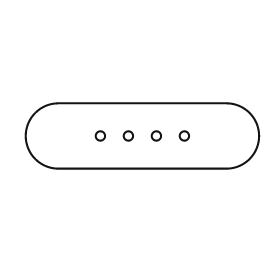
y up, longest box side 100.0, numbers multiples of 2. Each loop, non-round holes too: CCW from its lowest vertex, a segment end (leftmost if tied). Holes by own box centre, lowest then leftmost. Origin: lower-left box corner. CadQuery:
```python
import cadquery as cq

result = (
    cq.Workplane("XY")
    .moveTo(14.0, 0.0)
    .lineTo(86.0, 0.0)
    .threePointArc((100.0, 14.0), (86.0, 28.0))
    .lineTo(14.0, 28.0)
    .threePointArc((0.0, 14.0), (14.0, 0.0))
    .close()
    .moveTo(32.0, 14.0)
    .circle(2.0)
    .moveTo(44.0, 14.0)
    .circle(2.0)
    .moveTo(56.0, 14.0)
    .circle(2.0)
    .moveTo(68.0, 14.0)
    .circle(2.0)
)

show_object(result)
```